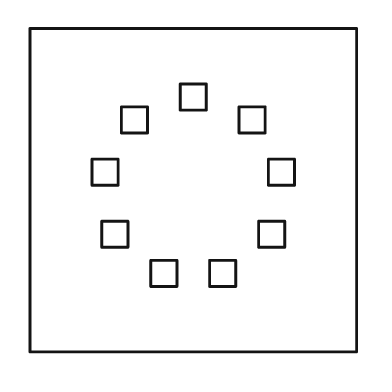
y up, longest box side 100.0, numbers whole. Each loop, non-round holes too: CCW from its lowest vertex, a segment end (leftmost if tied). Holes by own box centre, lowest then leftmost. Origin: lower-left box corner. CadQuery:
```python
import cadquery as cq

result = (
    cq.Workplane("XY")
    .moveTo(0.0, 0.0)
    .lineTo(100.0, 0.0)
    .lineTo(100.0, 99.0)
    .lineTo(0.0, 99.0)
    .close()
    .moveTo(37.0, 20.0)
    .lineTo(45.0, 20.0)
    .lineTo(45.0, 28.0)
    .lineTo(37.0, 28.0)
    .close()
    .moveTo(55.0, 20.0)
    .lineTo(63.0, 20.0)
    .lineTo(63.0, 28.0)
    .lineTo(55.0, 28.0)
    .close()
    .moveTo(22.0, 32.0)
    .lineTo(30.0, 32.0)
    .lineTo(30.0, 40.0)
    .lineTo(22.0, 40.0)
    .close()
    .moveTo(70.0, 32.0)
    .lineTo(78.0, 32.0)
    .lineTo(78.0, 40.0)
    .lineTo(70.0, 40.0)
    .close()
    .moveTo(19.0, 51.0)
    .lineTo(27.0, 51.0)
    .lineTo(27.0, 59.0)
    .lineTo(19.0, 59.0)
    .close()
    .moveTo(73.0, 51.0)
    .lineTo(81.0, 51.0)
    .lineTo(81.0, 59.0)
    .lineTo(73.0, 59.0)
    .close()
    .moveTo(28.0, 67.0)
    .lineTo(36.0, 67.0)
    .lineTo(36.0, 75.0)
    .lineTo(28.0, 75.0)
    .close()
    .moveTo(64.0, 67.0)
    .lineTo(72.0, 67.0)
    .lineTo(72.0, 75.0)
    .lineTo(64.0, 75.0)
    .close()
    .moveTo(46.0, 74.0)
    .lineTo(54.0, 74.0)
    .lineTo(54.0, 82.0)
    .lineTo(46.0, 82.0)
    .close()
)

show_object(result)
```